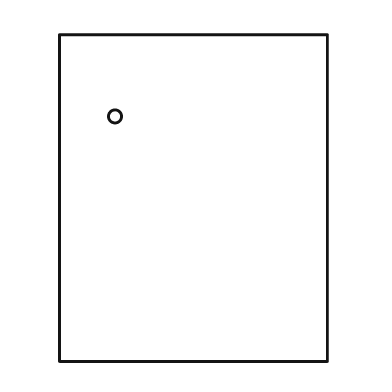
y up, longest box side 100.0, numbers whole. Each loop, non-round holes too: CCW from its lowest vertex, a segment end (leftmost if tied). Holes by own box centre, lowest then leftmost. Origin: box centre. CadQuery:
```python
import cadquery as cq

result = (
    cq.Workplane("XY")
    .moveTo(-41.0, -50.0)
    .lineTo(41.0, -50.0)
    .lineTo(41.0, 50.0)
    .lineTo(-41.0, 50.0)
    .close()
    .moveTo(-24.0, 25.0)
    .circle(2.0)
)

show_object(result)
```